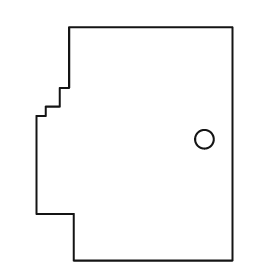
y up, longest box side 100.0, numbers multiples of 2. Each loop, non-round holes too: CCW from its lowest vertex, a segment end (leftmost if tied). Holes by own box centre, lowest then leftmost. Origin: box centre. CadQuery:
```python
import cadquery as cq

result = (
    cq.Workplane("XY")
    .moveTo(-26.0, -50.0)
    .lineTo(42.0, -50.0)
    .lineTo(42.0, 50.0)
    .lineTo(-28.0, 50.0)
    .lineTo(-28.0, 24.0)
    .lineTo(-32.0, 24.0)
    .lineTo(-32.0, 16.0)
    .lineTo(-38.0, 16.0)
    .lineTo(-38.0, 12.0)
    .lineTo(-42.0, 12.0)
    .lineTo(-42.0, -30.0)
    .lineTo(-26.0, -30.0)
    .close()
    .moveTo(30.0, 2.0)
    .circle(4.0)
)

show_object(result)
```